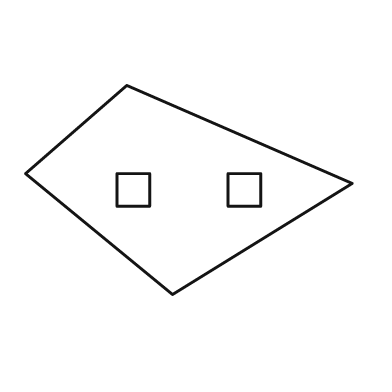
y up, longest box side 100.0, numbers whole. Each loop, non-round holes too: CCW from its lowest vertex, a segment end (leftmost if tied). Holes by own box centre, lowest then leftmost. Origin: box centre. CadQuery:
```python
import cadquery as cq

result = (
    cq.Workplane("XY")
    .moveTo(-5.0, -32.0)
    .lineTo(50.0, 2.0)
    .lineTo(-19.0, 32.0)
    .lineTo(-50.0, 5.0)
    .close()
    .moveTo(-22.0, -5.0)
    .lineTo(-12.0, -5.0)
    .lineTo(-12.0, 5.0)
    .lineTo(-22.0, 5.0)
    .close()
    .moveTo(12.0, -5.0)
    .lineTo(22.0, -5.0)
    .lineTo(22.0, 5.0)
    .lineTo(12.0, 5.0)
    .close()
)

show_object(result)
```